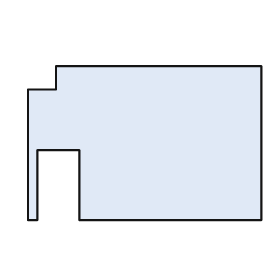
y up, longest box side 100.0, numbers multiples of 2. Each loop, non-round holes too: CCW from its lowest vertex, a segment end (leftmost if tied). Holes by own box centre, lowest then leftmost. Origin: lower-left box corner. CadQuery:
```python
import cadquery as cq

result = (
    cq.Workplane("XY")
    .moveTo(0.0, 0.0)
    .lineTo(4.0, 0.0)
    .lineTo(4.0, 30.0)
    .lineTo(22.0, 30.0)
    .lineTo(22.0, 0.0)
    .lineTo(100.0, 0.0)
    .lineTo(100.0, 66.0)
    .lineTo(12.0, 66.0)
    .lineTo(12.0, 56.0)
    .lineTo(0.0, 56.0)
    .close()
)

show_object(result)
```